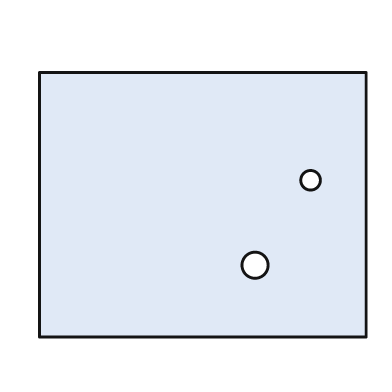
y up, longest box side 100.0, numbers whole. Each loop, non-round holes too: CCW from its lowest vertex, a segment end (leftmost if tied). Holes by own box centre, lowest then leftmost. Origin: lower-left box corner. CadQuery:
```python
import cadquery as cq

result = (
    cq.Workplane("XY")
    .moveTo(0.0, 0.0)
    .lineTo(100.0, 0.0)
    .lineTo(100.0, 81.0)
    .lineTo(0.0, 81.0)
    .close()
    .moveTo(66.0, 22.0)
    .circle(4.0)
    .moveTo(83.0, 48.0)
    .circle(3.0)
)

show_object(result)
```